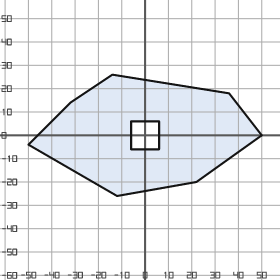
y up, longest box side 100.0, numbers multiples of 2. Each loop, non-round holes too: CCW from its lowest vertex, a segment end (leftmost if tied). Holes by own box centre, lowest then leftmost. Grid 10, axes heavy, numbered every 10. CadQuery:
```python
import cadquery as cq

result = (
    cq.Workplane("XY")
    .moveTo(-12.0, -26.0)
    .lineTo(22.0, -20.0)
    .lineTo(50.0, 0.0)
    .lineTo(36.0, 18.0)
    .lineTo(-14.0, 26.0)
    .lineTo(-32.0, 14.0)
    .lineTo(-50.0, -4.0)
    .close()
    .moveTo(-6.0, -6.0)
    .lineTo(6.0, -6.0)
    .lineTo(6.0, 6.0)
    .lineTo(-6.0, 6.0)
    .close()
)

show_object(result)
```